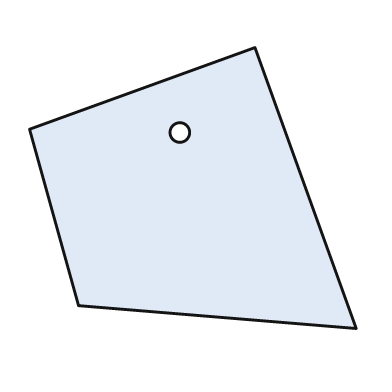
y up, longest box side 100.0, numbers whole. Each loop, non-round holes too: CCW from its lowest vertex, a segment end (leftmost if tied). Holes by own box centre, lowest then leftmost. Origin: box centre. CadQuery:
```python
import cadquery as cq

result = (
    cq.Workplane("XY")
    .moveTo(50.0, -43.0)
    .lineTo(19.0, 43.0)
    .lineTo(-50.0, 18.0)
    .lineTo(-35.0, -36.0)
    .close()
    .moveTo(-4.0, 17.0)
    .circle(3.0)
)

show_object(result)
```